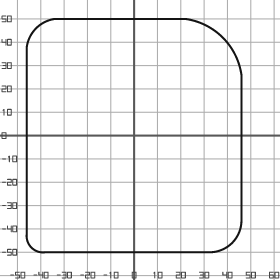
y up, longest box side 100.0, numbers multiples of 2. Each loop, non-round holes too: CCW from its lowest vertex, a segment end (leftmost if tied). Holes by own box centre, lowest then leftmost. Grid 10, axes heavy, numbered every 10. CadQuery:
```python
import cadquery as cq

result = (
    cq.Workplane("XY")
    .moveTo(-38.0, -50.0)
    .lineTo(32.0, -50.0)
    .threePointArc((42.0, -46.0), (46.0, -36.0))
    .lineTo(46.0, 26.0)
    .threePointArc((38.0, 42.0), (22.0, 50.0))
    .lineTo(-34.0, 50.0)
    .threePointArc((-42.0, 46.0), (-46.0, 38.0))
    .lineTo(-46.0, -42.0)
    .threePointArc((-44.0, -48.0), (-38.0, -50.0))
    .close()
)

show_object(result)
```